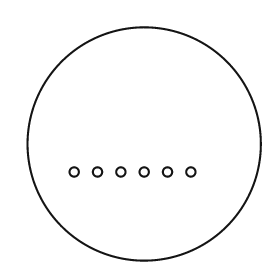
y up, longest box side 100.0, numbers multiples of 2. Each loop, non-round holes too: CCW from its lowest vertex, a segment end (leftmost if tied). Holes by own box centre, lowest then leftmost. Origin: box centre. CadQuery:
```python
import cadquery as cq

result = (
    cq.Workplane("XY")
    .moveTo(0.0, 0.0)
    .circle(50.0)
    .moveTo(-30.0, -12.0)
    .circle(2.0)
    .moveTo(-20.0, -12.0)
    .circle(2.0)
    .moveTo(-10.0, -12.0)
    .circle(2.0)
    .moveTo(0.0, -12.0)
    .circle(2.0)
    .moveTo(10.0, -12.0)
    .circle(2.0)
    .moveTo(20.0, -12.0)
    .circle(2.0)
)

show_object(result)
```